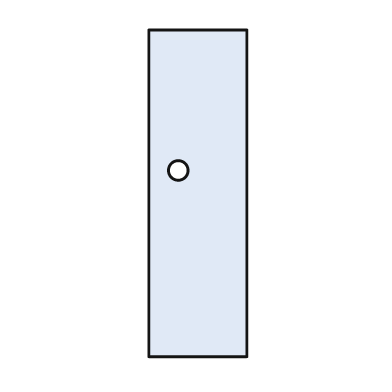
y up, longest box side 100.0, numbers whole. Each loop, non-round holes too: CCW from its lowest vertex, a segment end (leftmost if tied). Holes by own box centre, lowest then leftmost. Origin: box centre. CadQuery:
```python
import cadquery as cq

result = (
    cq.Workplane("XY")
    .moveTo(-15.0, -50.0)
    .lineTo(15.0, -50.0)
    .lineTo(15.0, 50.0)
    .lineTo(-15.0, 50.0)
    .close()
    .moveTo(-6.0, 7.0)
    .circle(3.0)
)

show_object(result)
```